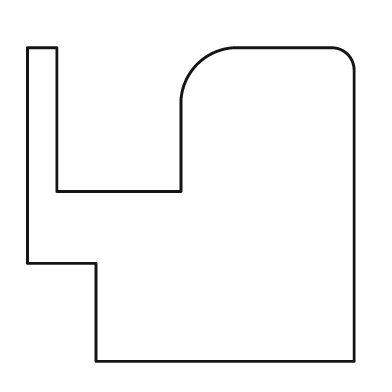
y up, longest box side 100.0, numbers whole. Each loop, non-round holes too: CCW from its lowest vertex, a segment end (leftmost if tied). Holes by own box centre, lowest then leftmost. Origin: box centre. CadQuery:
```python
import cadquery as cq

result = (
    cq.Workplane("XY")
    .moveTo(-29.0, -48.0)
    .lineTo(50.0, -48.0)
    .lineTo(50.0, 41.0)
    .threePointArc((48.0, 46.0), (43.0, 48.0))
    .lineTo(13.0, 48.0)
    .threePointArc((2.0, 43.0), (-3.0, 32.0))
    .lineTo(-3.0, 4.0)
    .lineTo(-41.0, 4.0)
    .lineTo(-41.0, 48.0)
    .lineTo(-50.0, 48.0)
    .lineTo(-50.0, -18.0)
    .lineTo(-29.0, -18.0)
    .close()
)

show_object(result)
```